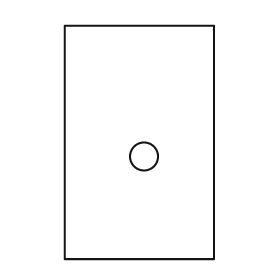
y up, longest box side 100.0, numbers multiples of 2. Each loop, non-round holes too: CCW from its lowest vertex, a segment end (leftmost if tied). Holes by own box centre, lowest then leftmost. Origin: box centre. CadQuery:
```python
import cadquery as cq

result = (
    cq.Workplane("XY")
    .moveTo(-32.0, -50.0)
    .lineTo(32.0, -50.0)
    .lineTo(32.0, 50.0)
    .lineTo(-32.0, 50.0)
    .close()
    .moveTo(2.0, -6.0)
    .circle(6.0)
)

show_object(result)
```